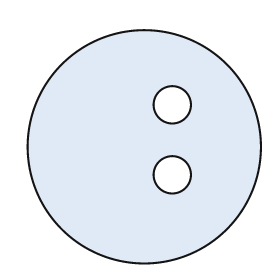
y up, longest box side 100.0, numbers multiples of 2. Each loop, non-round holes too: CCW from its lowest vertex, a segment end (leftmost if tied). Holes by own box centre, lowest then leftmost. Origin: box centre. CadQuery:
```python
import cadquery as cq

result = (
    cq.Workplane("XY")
    .moveTo(0.0, 0.0)
    .circle(50.0)
    .moveTo(12.0, -12.0)
    .circle(8.0)
    .moveTo(12.0, 18.0)
    .circle(8.0)
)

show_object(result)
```